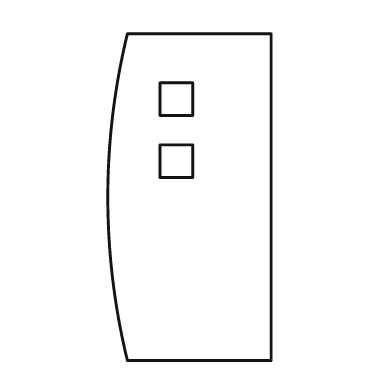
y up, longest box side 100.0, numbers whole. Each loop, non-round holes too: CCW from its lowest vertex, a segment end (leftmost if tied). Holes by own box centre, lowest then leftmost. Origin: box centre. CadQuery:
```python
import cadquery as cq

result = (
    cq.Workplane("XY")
    .moveTo(-19.0, -50.0)
    .lineTo(25.0, -50.0)
    .lineTo(25.0, 50.0)
    .lineTo(-19.0, 50.0)
    .threePointArc((-25.0, 0.0), (-19.0, -50.0))
    .close()
    .moveTo(-9.0, 6.0)
    .lineTo(1.0, 6.0)
    .lineTo(1.0, 16.0)
    .lineTo(-9.0, 16.0)
    .close()
    .moveTo(-9.0, 25.0)
    .lineTo(1.0, 25.0)
    .lineTo(1.0, 35.0)
    .lineTo(-9.0, 35.0)
    .close()
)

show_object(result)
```